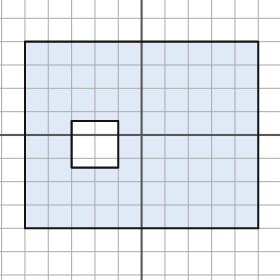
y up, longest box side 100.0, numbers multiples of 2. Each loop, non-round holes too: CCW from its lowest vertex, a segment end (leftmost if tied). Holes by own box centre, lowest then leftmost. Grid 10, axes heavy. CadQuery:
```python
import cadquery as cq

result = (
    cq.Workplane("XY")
    .moveTo(-50.0, -40.0)
    .lineTo(50.0, -40.0)
    .lineTo(50.0, 40.0)
    .lineTo(-50.0, 40.0)
    .close()
    .moveTo(-30.0, -14.0)
    .lineTo(-10.0, -14.0)
    .lineTo(-10.0, 6.0)
    .lineTo(-30.0, 6.0)
    .close()
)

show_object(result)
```